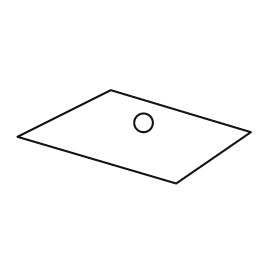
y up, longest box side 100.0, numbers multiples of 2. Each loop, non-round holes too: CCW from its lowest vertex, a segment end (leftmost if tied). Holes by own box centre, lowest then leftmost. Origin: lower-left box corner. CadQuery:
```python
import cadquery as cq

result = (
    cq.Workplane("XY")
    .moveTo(68.0, 0.0)
    .lineTo(100.0, 22.0)
    .lineTo(40.0, 40.0)
    .lineTo(0.0, 20.0)
    .close()
    .moveTo(54.0, 26.0)
    .circle(4.0)
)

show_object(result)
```